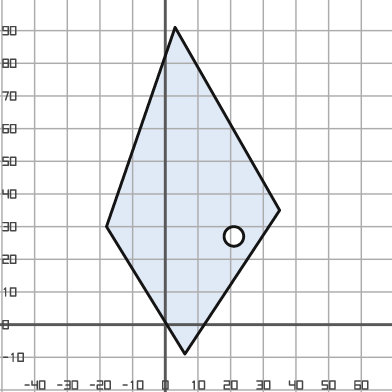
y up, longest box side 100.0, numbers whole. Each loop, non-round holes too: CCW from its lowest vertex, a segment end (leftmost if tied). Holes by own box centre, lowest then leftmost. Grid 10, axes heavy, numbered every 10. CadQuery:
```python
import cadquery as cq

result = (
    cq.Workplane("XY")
    .moveTo(6.0, -9.0)
    .lineTo(35.0, 35.0)
    .lineTo(3.0, 91.0)
    .lineTo(-18.0, 30.0)
    .close()
    .moveTo(21.0, 27.0)
    .circle(3.0)
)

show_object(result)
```